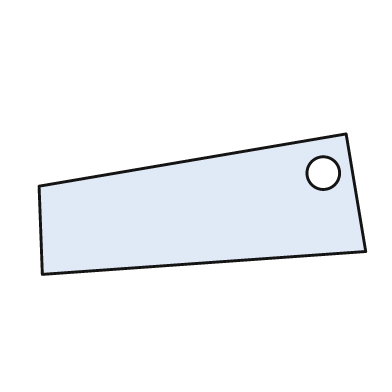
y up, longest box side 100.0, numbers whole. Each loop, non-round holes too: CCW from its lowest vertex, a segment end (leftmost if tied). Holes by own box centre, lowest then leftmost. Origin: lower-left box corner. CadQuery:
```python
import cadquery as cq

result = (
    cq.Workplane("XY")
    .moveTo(1.0, 0.0)
    .lineTo(100.0, 7.0)
    .lineTo(94.0, 43.0)
    .lineTo(0.0, 27.0)
    .close()
    .moveTo(87.0, 31.0)
    .circle(5.0)
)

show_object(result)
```